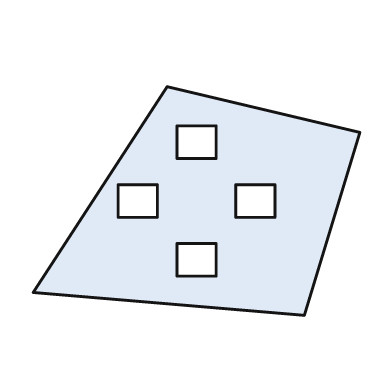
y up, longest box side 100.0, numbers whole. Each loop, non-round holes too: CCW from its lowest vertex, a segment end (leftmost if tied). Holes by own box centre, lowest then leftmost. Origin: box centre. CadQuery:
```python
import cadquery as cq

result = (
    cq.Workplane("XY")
    .moveTo(33.0, -35.0)
    .lineTo(50.0, 21.0)
    .lineTo(-9.0, 35.0)
    .lineTo(-50.0, -28.0)
    .close()
    .moveTo(-6.0, -23.0)
    .lineTo(6.0, -23.0)
    .lineTo(6.0, -13.0)
    .lineTo(-6.0, -13.0)
    .close()
    .moveTo(-24.0, -5.0)
    .lineTo(-12.0, -5.0)
    .lineTo(-12.0, 5.0)
    .lineTo(-24.0, 5.0)
    .close()
    .moveTo(12.0, -5.0)
    .lineTo(24.0, -5.0)
    .lineTo(24.0, 5.0)
    .lineTo(12.0, 5.0)
    .close()
    .moveTo(-6.0, 13.0)
    .lineTo(6.0, 13.0)
    .lineTo(6.0, 23.0)
    .lineTo(-6.0, 23.0)
    .close()
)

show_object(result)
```